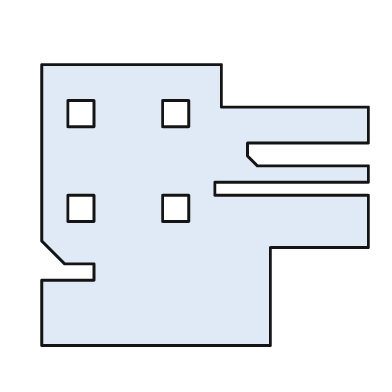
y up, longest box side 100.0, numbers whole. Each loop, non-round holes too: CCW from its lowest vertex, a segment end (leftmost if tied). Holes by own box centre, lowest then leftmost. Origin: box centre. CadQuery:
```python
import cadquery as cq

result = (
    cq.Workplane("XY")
    .moveTo(-50.0, -43.0)
    .lineTo(20.0, -43.0)
    .lineTo(20.0, -13.0)
    .lineTo(50.0, -13.0)
    .lineTo(50.0, 3.0)
    .lineTo(3.0, 3.0)
    .lineTo(3.0, 7.0)
    .lineTo(50.0, 7.0)
    .lineTo(50.0, 12.0)
    .lineTo(16.0, 12.0)
    .lineTo(13.0, 15.0)
    .lineTo(13.0, 19.0)
    .lineTo(50.0, 19.0)
    .lineTo(50.0, 30.0)
    .lineTo(5.0, 30.0)
    .lineTo(5.0, 43.0)
    .lineTo(-50.0, 43.0)
    .lineTo(-50.0, -11.0)
    .lineTo(-43.0, -18.0)
    .lineTo(-34.0, -18.0)
    .lineTo(-34.0, -23.0)
    .lineTo(-50.0, -23.0)
    .close()
    .moveTo(-42.0, -5.0)
    .lineTo(-34.0, -5.0)
    .lineTo(-34.0, 3.0)
    .lineTo(-42.0, 3.0)
    .close()
    .moveTo(-13.0, -5.0)
    .lineTo(-5.0, -5.0)
    .lineTo(-5.0, 3.0)
    .lineTo(-13.0, 3.0)
    .close()
    .moveTo(-42.0, 24.0)
    .lineTo(-34.0, 24.0)
    .lineTo(-34.0, 32.0)
    .lineTo(-42.0, 32.0)
    .close()
    .moveTo(-13.0, 24.0)
    .lineTo(-5.0, 24.0)
    .lineTo(-5.0, 32.0)
    .lineTo(-13.0, 32.0)
    .close()
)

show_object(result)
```